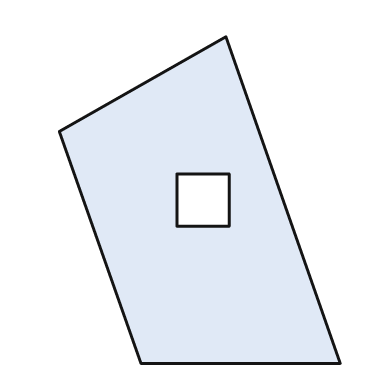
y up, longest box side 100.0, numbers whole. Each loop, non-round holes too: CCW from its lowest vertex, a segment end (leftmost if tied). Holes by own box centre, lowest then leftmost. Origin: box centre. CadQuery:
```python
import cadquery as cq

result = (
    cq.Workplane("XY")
    .moveTo(-18.0, -50.0)
    .lineTo(43.0, -50.0)
    .lineTo(8.0, 50.0)
    .lineTo(-43.0, 21.0)
    .close()
    .moveTo(-7.0, -8.0)
    .lineTo(9.0, -8.0)
    .lineTo(9.0, 8.0)
    .lineTo(-7.0, 8.0)
    .close()
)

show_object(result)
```